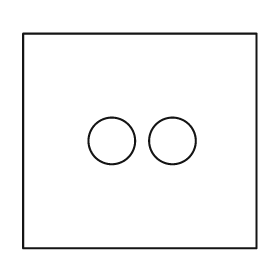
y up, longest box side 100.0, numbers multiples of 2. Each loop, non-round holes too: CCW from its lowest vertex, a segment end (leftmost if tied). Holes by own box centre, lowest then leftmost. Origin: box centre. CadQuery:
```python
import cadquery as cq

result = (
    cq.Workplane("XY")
    .moveTo(-50.0, -46.0)
    .lineTo(50.0, -46.0)
    .lineTo(50.0, 46.0)
    .lineTo(-50.0, 46.0)
    .close()
    .moveTo(-12.0, 0.0)
    .circle(10.0)
    .moveTo(14.0, 0.0)
    .circle(10.0)
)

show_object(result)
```